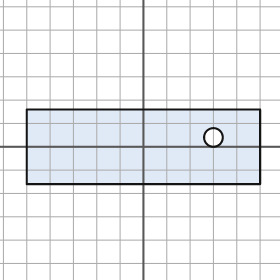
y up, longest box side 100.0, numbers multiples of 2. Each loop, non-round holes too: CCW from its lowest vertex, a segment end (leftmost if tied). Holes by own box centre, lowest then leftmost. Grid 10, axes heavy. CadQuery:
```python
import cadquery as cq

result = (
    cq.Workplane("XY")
    .moveTo(-50.0, -16.0)
    .lineTo(50.0, -16.0)
    .lineTo(50.0, 16.0)
    .lineTo(-50.0, 16.0)
    .close()
    .moveTo(30.0, 4.0)
    .circle(4.0)
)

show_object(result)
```